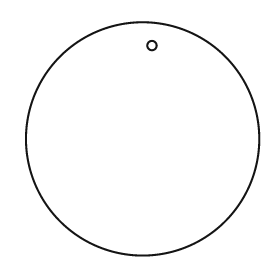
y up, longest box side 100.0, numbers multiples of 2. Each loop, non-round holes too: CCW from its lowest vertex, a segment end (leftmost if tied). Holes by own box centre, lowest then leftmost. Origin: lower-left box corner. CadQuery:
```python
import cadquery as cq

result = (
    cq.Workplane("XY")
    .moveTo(50.0, 50.0)
    .circle(50.0)
    .moveTo(54.0, 90.0)
    .circle(2.0)
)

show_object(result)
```